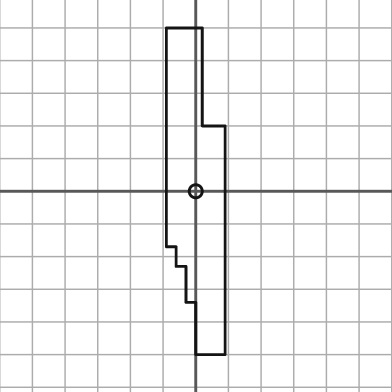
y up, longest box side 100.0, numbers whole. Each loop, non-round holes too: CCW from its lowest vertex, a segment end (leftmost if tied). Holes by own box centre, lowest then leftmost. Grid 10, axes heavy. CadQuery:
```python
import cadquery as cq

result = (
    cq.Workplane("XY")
    .moveTo(0.0, -50.0)
    .lineTo(9.0, -50.0)
    .lineTo(9.0, 20.0)
    .lineTo(2.0, 20.0)
    .lineTo(2.0, 50.0)
    .lineTo(-9.0, 50.0)
    .lineTo(-9.0, -17.0)
    .lineTo(-6.0, -17.0)
    .lineTo(-6.0, -23.0)
    .lineTo(-3.0, -23.0)
    .lineTo(-3.0, -34.0)
    .lineTo(0.0, -34.0)
    .close()
    .moveTo(0.0, 0.0)
    .circle(2.0)
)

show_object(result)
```